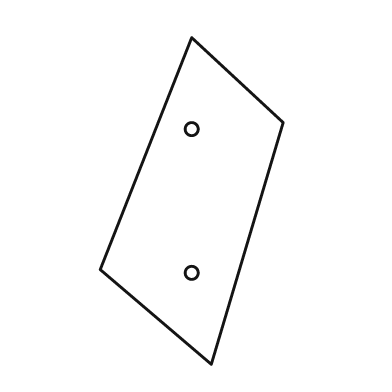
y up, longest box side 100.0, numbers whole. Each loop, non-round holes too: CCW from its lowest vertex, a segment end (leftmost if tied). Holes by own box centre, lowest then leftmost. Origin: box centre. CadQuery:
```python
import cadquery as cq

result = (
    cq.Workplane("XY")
    .moveTo(6.0, -50.0)
    .lineTo(28.0, 24.0)
    .lineTo(0.0, 50.0)
    .lineTo(-28.0, -21.0)
    .close()
    .moveTo(0.0, -22.0)
    .circle(2.0)
    .moveTo(0.0, 22.0)
    .circle(2.0)
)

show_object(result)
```